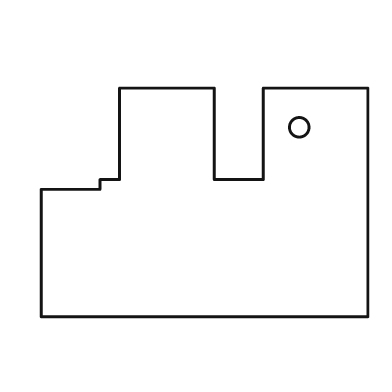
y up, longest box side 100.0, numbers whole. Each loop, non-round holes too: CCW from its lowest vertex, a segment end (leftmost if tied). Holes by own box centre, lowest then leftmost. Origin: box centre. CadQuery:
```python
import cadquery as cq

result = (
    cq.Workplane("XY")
    .moveTo(-50.0, -35.0)
    .lineTo(50.0, -35.0)
    .lineTo(50.0, 35.0)
    .lineTo(18.0, 35.0)
    .lineTo(18.0, 7.0)
    .lineTo(3.0, 7.0)
    .lineTo(3.0, 35.0)
    .lineTo(-26.0, 35.0)
    .lineTo(-26.0, 7.0)
    .lineTo(-32.0, 7.0)
    .lineTo(-32.0, 4.0)
    .lineTo(-50.0, 4.0)
    .close()
    .moveTo(29.0, 23.0)
    .circle(3.0)
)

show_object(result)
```